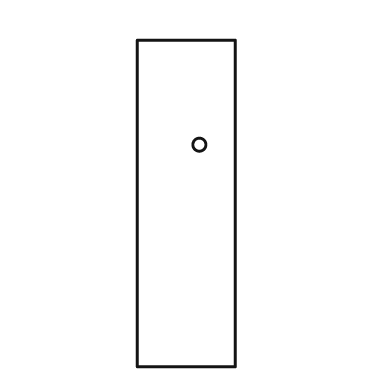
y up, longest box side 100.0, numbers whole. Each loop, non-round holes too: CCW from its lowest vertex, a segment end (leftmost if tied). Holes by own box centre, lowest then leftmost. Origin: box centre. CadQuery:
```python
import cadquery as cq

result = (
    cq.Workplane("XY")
    .moveTo(-15.0, -50.0)
    .lineTo(15.0, -50.0)
    .lineTo(15.0, 50.0)
    .lineTo(-15.0, 50.0)
    .close()
    .moveTo(4.0, 18.0)
    .circle(2.0)
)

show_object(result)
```